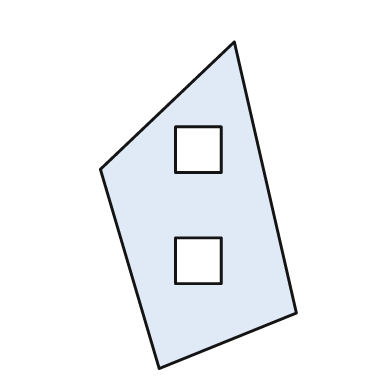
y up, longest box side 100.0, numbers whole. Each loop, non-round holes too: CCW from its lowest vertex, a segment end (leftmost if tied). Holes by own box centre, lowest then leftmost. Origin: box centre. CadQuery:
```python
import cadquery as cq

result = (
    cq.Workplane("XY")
    .moveTo(-12.0, -50.0)
    .lineTo(30.0, -33.0)
    .lineTo(11.0, 50.0)
    .lineTo(-30.0, 11.0)
    .close()
    .moveTo(-7.0, -24.0)
    .lineTo(7.0, -24.0)
    .lineTo(7.0, -10.0)
    .lineTo(-7.0, -10.0)
    .close()
    .moveTo(-7.0, 10.0)
    .lineTo(7.0, 10.0)
    .lineTo(7.0, 24.0)
    .lineTo(-7.0, 24.0)
    .close()
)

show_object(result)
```